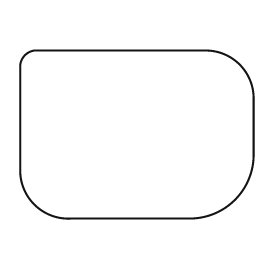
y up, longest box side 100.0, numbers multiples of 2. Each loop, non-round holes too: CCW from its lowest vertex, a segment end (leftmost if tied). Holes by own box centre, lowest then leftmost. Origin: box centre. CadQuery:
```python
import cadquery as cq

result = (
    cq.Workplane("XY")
    .moveTo(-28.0, -36.0)
    .lineTo(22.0, -36.0)
    .threePointArc((42.0, -28.0), (50.0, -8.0))
    .lineTo(50.0, 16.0)
    .threePointArc((44.0, 30.0), (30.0, 36.0))
    .lineTo(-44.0, 36.0)
    .threePointArc((-48.0, 34.0), (-50.0, 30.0))
    .lineTo(-50.0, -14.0)
    .threePointArc((-44.0, -30.0), (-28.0, -36.0))
    .close()
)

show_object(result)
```